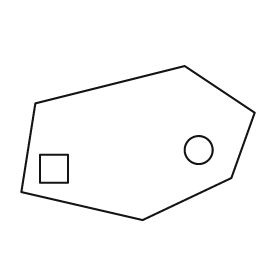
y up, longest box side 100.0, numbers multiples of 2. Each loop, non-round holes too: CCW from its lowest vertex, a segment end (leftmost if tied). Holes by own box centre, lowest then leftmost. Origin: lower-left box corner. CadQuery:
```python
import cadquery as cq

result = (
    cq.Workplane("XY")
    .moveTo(52.0, 0.0)
    .lineTo(90.0, 18.0)
    .lineTo(100.0, 46.0)
    .lineTo(70.0, 66.0)
    .lineTo(6.0, 50.0)
    .lineTo(0.0, 12.0)
    .close()
    .moveTo(8.0, 16.0)
    .lineTo(20.0, 16.0)
    .lineTo(20.0, 28.0)
    .lineTo(8.0, 28.0)
    .close()
    .moveTo(76.0, 30.0)
    .circle(6.0)
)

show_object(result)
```